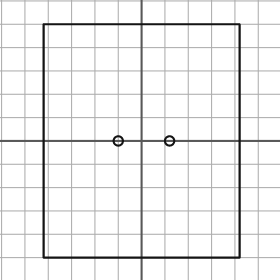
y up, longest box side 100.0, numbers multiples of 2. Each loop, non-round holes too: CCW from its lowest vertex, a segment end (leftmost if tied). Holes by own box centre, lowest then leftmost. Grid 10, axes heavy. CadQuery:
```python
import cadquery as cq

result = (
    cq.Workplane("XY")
    .moveTo(-42.0, -50.0)
    .lineTo(42.0, -50.0)
    .lineTo(42.0, 50.0)
    .lineTo(-42.0, 50.0)
    .close()
    .moveTo(-10.0, 0.0)
    .circle(2.0)
    .moveTo(12.0, 0.0)
    .circle(2.0)
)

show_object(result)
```